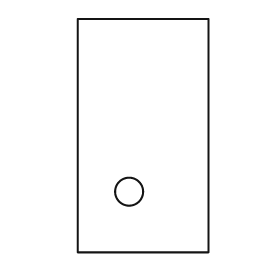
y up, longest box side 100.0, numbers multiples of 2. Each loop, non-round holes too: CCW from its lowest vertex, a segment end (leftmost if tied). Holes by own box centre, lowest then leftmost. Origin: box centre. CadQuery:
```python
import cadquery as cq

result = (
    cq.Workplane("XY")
    .moveTo(-28.0, -50.0)
    .lineTo(28.0, -50.0)
    .lineTo(28.0, 50.0)
    .lineTo(-28.0, 50.0)
    .close()
    .moveTo(-6.0, -24.0)
    .circle(6.0)
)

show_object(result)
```